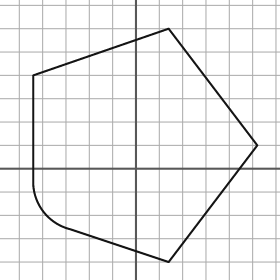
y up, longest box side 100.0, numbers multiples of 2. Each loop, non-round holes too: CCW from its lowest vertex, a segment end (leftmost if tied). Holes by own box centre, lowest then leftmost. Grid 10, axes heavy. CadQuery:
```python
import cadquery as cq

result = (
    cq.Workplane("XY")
    .moveTo(14.0, -40.0)
    .lineTo(52.0, 10.0)
    .lineTo(14.0, 60.0)
    .lineTo(-44.0, 40.0)
    .lineTo(-44.0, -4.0)
    .threePointArc((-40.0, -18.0), (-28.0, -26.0))
    .close()
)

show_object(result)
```